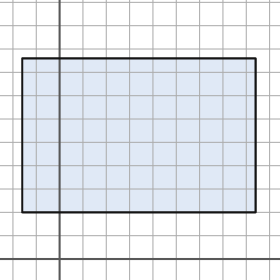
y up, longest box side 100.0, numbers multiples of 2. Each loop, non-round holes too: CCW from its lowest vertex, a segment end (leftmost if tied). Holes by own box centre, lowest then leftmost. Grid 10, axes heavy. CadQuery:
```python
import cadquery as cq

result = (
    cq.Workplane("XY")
    .moveTo(-16.0, 20.0)
    .lineTo(84.0, 20.0)
    .lineTo(84.0, 86.0)
    .lineTo(-16.0, 86.0)
    .close()
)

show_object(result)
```